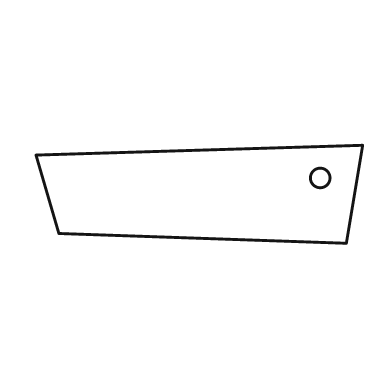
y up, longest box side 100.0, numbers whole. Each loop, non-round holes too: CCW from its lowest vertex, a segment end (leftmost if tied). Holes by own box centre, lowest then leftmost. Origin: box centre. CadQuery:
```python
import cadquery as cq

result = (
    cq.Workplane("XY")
    .moveTo(45.0, -15.0)
    .lineTo(50.0, 15.0)
    .lineTo(-50.0, 12.0)
    .lineTo(-43.0, -12.0)
    .close()
    .moveTo(37.0, 5.0)
    .circle(3.0)
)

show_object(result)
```